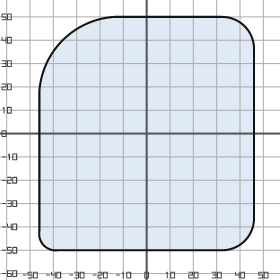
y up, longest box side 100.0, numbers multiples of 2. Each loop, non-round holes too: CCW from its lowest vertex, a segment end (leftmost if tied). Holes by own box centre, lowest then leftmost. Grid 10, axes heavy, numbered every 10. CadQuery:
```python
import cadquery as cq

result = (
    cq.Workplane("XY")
    .moveTo(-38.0, -50.0)
    .lineTo(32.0, -50.0)
    .threePointArc((42.0, -46.0), (46.0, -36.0))
    .lineTo(46.0, 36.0)
    .threePointArc((42.0, 46.0), (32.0, 50.0))
    .lineTo(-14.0, 50.0)
    .threePointArc((-36.0, 40.0), (-46.0, 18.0))
    .lineTo(-46.0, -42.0)
    .threePointArc((-44.0, -48.0), (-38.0, -50.0))
    .close()
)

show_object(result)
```